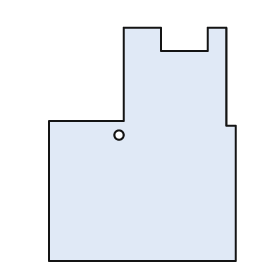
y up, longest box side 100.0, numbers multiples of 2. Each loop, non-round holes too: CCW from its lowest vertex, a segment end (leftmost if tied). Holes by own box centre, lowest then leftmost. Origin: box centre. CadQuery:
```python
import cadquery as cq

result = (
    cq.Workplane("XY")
    .moveTo(-40.0, -50.0)
    .lineTo(40.0, -50.0)
    .lineTo(40.0, 8.0)
    .lineTo(36.0, 8.0)
    .lineTo(36.0, 50.0)
    .lineTo(28.0, 50.0)
    .lineTo(28.0, 40.0)
    .lineTo(8.0, 40.0)
    .lineTo(8.0, 50.0)
    .lineTo(-8.0, 50.0)
    .lineTo(-8.0, 10.0)
    .lineTo(-40.0, 10.0)
    .close()
    .moveTo(-10.0, 4.0)
    .circle(2.0)
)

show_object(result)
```